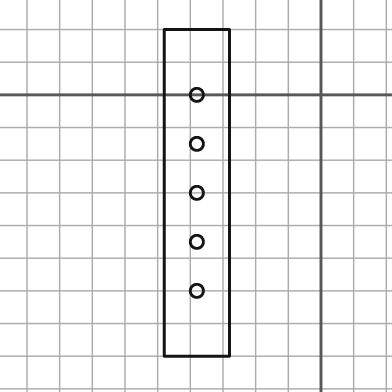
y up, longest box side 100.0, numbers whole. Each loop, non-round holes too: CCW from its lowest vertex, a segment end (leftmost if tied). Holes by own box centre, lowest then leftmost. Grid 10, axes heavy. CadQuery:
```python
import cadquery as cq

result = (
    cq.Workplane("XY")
    .moveTo(-48.0, -80.0)
    .lineTo(-28.0, -80.0)
    .lineTo(-28.0, 20.0)
    .lineTo(-48.0, 20.0)
    .close()
    .moveTo(-38.0, -60.0)
    .circle(2.0)
    .moveTo(-38.0, -45.0)
    .circle(2.0)
    .moveTo(-38.0, -30.0)
    .circle(2.0)
    .moveTo(-38.0, -15.0)
    .circle(2.0)
    .moveTo(-38.0, 0.0)
    .circle(2.0)
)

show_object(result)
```